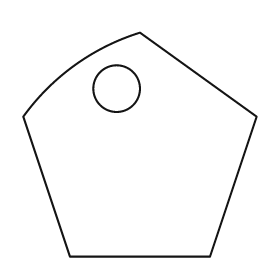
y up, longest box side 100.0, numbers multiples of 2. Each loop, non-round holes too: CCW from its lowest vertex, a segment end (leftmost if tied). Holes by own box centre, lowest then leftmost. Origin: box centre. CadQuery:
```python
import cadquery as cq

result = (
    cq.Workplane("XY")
    .moveTo(-30.0, -48.0)
    .lineTo(30.0, -48.0)
    .lineTo(50.0, 12.0)
    .lineTo(0.0, 48.0)
    .threePointArc((-28.0, 34.0), (-50.0, 12.0))
    .close()
    .moveTo(-10.0, 24.0)
    .circle(10.0)
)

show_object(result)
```